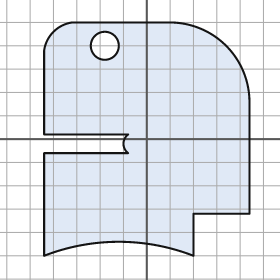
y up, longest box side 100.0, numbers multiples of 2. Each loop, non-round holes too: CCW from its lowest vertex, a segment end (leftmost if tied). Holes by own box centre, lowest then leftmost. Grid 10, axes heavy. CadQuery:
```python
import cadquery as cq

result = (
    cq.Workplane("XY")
    .moveTo(-44.0, -50.0)
    .threePointArc((-12.0, -44.0), (20.0, -50.0))
    .lineTo(20.0, -32.0)
    .lineTo(44.0, -32.0)
    .lineTo(44.0, 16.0)
    .threePointArc((34.0, 40.0), (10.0, 50.0))
    .lineTo(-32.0, 50.0)
    .threePointArc((-40.0, 46.0), (-44.0, 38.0))
    .lineTo(-44.0, 2.0)
    .lineTo(-8.0, 2.0)
    .threePointArc((-10.0, -2.0), (-8.0, -6.0))
    .lineTo(-44.0, -6.0)
    .close()
    .moveTo(-18.0, 40.0)
    .circle(6.0)
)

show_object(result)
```